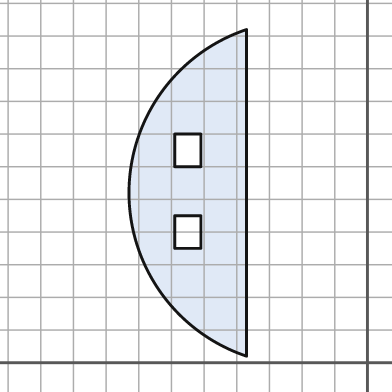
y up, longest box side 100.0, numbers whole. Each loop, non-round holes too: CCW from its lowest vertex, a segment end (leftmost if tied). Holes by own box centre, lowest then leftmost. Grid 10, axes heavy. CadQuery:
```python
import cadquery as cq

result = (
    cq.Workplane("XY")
    .moveTo(-37.0, 2.0)
    .lineTo(-37.0, 102.0)
    .threePointArc((-73.0, 52.0), (-37.0, 2.0))
    .close()
    .moveTo(-59.0, 35.0)
    .lineTo(-51.0, 35.0)
    .lineTo(-51.0, 45.0)
    .lineTo(-59.0, 45.0)
    .close()
    .moveTo(-59.0, 60.0)
    .lineTo(-51.0, 60.0)
    .lineTo(-51.0, 70.0)
    .lineTo(-59.0, 70.0)
    .close()
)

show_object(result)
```